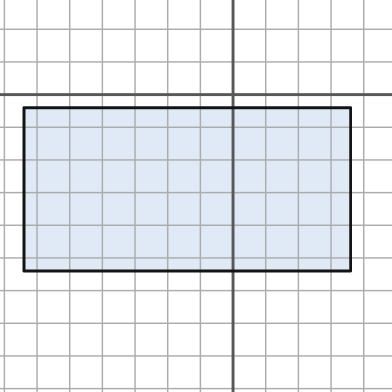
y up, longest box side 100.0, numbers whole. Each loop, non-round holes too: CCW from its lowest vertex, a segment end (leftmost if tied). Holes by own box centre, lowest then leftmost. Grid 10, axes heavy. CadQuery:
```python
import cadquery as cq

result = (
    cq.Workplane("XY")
    .moveTo(-64.0, -54.0)
    .lineTo(36.0, -54.0)
    .lineTo(36.0, -4.0)
    .lineTo(-64.0, -4.0)
    .close()
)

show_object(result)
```